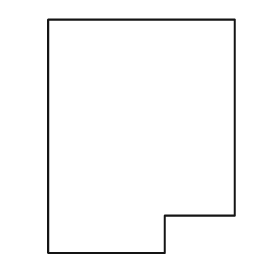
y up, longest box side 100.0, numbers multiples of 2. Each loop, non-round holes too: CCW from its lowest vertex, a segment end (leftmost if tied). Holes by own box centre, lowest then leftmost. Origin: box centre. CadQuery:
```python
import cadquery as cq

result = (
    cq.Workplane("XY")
    .moveTo(-40.0, -50.0)
    .lineTo(10.0, -50.0)
    .lineTo(10.0, -34.0)
    .lineTo(40.0, -34.0)
    .lineTo(40.0, 50.0)
    .lineTo(-40.0, 50.0)
    .close()
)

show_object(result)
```